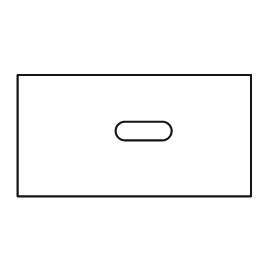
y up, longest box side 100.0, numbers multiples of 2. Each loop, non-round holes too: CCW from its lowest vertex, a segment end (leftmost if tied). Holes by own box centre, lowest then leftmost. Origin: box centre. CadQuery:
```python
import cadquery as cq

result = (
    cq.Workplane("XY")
    .moveTo(-50.0, -26.0)
    .lineTo(50.0, -26.0)
    .lineTo(50.0, 26.0)
    .lineTo(-50.0, 26.0)
    .close()
    .moveTo(-4.0, -2.0)
    .lineTo(12.0, -2.0)
    .threePointArc((16.0, 2.0), (12.0, 6.0))
    .lineTo(-4.0, 6.0)
    .threePointArc((-8.0, 2.0), (-4.0, -2.0))
    .close()
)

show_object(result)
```